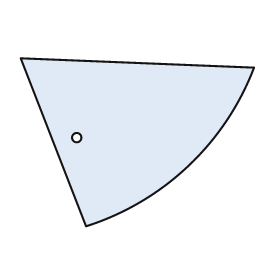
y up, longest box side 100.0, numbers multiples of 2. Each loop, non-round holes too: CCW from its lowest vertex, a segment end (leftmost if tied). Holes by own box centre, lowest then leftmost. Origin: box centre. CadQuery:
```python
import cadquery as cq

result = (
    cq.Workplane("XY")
    .moveTo(-22.0, -36.0)
    .threePointArc((22.0, -10.0), (50.0, 32.0))
    .lineTo(-50.0, 36.0)
    .close()
    .moveTo(-26.0, 2.0)
    .circle(2.0)
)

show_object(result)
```